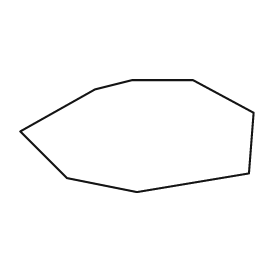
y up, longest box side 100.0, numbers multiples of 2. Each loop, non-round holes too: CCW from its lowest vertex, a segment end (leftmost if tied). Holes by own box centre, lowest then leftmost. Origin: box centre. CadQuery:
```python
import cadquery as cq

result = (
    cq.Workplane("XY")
    .moveTo(0.0, -24.0)
    .lineTo(48.0, -16.0)
    .lineTo(50.0, 10.0)
    .lineTo(24.0, 24.0)
    .lineTo(-2.0, 24.0)
    .lineTo(-18.0, 20.0)
    .lineTo(-50.0, 2.0)
    .lineTo(-30.0, -18.0)
    .close()
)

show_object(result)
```